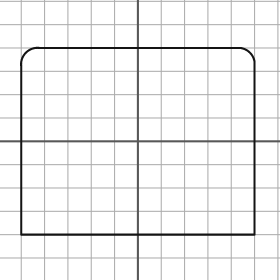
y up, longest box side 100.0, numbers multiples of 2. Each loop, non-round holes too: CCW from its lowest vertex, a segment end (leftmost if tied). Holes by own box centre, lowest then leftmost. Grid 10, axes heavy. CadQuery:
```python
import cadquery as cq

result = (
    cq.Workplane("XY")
    .moveTo(-50.0, -40.0)
    .lineTo(50.0, -40.0)
    .lineTo(50.0, 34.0)
    .threePointArc((48.0, 38.0), (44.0, 40.0))
    .lineTo(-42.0, 40.0)
    .threePointArc((-48.0, 38.0), (-50.0, 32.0))
    .close()
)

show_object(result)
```